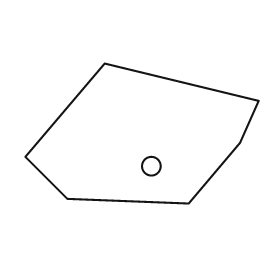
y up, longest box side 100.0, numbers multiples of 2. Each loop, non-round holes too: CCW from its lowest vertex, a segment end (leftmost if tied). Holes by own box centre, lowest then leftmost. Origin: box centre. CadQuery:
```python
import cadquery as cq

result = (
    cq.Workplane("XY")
    .moveTo(20.0, -30.0)
    .lineTo(42.0, -4.0)
    .lineTo(50.0, 14.0)
    .lineTo(-16.0, 30.0)
    .lineTo(-50.0, -10.0)
    .lineTo(-32.0, -28.0)
    .close()
    .moveTo(4.0, -14.0)
    .circle(4.0)
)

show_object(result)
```